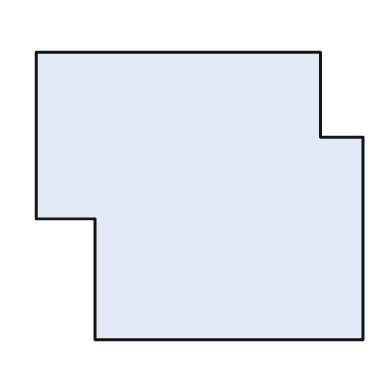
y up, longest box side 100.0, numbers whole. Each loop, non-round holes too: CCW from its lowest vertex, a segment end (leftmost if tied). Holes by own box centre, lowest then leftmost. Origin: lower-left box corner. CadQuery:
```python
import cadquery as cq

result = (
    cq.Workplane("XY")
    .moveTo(18.0, 0.0)
    .lineTo(100.0, 0.0)
    .lineTo(100.0, 62.0)
    .lineTo(87.0, 62.0)
    .lineTo(87.0, 88.0)
    .lineTo(0.0, 88.0)
    .lineTo(0.0, 37.0)
    .lineTo(18.0, 37.0)
    .close()
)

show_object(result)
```